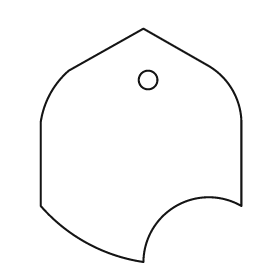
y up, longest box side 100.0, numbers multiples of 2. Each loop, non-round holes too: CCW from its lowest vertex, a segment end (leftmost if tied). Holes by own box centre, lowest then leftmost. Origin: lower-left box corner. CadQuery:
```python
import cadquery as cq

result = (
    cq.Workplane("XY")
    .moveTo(44.0, 0.0)
    .threePointArc((58.0, 24.0), (86.0, 24.0))
    .lineTo(86.0, 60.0)
    .threePointArc((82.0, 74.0), (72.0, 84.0))
    .lineTo(44.0, 100.0)
    .lineTo(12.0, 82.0)
    .threePointArc((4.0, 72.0), (0.0, 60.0))
    .lineTo(0.0, 24.0)
    .threePointArc((20.0, 8.0), (44.0, 0.0))
    .close()
    .moveTo(46.0, 78.0)
    .circle(4.0)
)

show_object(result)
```